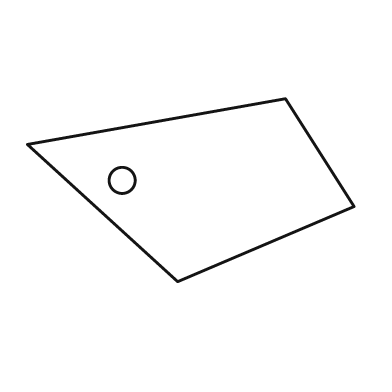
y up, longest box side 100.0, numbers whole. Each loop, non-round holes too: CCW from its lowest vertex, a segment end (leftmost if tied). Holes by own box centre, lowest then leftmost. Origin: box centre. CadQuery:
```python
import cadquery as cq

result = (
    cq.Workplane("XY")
    .moveTo(-4.0, -28.0)
    .lineTo(50.0, -5.0)
    .lineTo(29.0, 28.0)
    .lineTo(-50.0, 14.0)
    .close()
    .moveTo(-21.0, 3.0)
    .circle(4.0)
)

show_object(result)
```